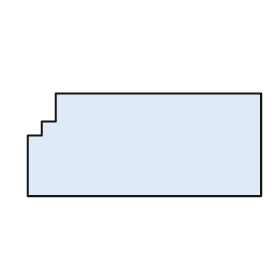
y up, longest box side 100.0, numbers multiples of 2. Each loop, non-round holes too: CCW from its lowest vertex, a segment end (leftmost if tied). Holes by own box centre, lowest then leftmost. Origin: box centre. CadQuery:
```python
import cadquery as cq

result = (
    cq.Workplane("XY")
    .moveTo(-50.0, -22.0)
    .lineTo(50.0, -22.0)
    .lineTo(50.0, 22.0)
    .lineTo(-38.0, 22.0)
    .lineTo(-38.0, 10.0)
    .lineTo(-44.0, 10.0)
    .lineTo(-44.0, 4.0)
    .lineTo(-50.0, 4.0)
    .close()
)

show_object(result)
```